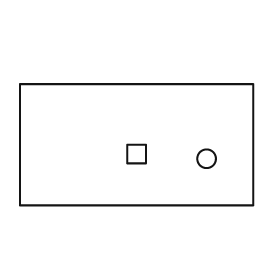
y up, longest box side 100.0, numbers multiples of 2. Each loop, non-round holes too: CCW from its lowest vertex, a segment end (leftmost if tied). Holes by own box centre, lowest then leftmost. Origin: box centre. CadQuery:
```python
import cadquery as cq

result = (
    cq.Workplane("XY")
    .moveTo(-50.0, -26.0)
    .lineTo(50.0, -26.0)
    .lineTo(50.0, 26.0)
    .lineTo(-50.0, 26.0)
    .close()
    .moveTo(30.0, -6.0)
    .circle(4.0)
    .moveTo(-4.0, -8.0)
    .lineTo(4.0, -8.0)
    .lineTo(4.0, 0.0)
    .lineTo(-4.0, 0.0)
    .close()
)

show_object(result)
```